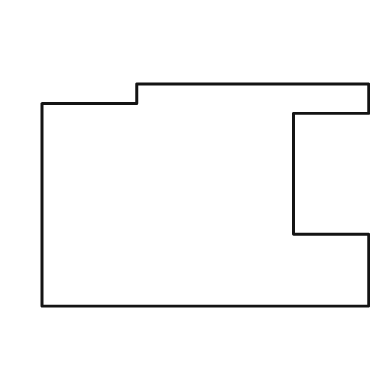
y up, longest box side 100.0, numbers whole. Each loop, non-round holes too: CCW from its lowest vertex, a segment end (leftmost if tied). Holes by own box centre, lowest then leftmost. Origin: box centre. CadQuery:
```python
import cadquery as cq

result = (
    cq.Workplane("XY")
    .moveTo(-50.0, -34.0)
    .lineTo(50.0, -34.0)
    .lineTo(50.0, -12.0)
    .lineTo(27.0, -12.0)
    .lineTo(27.0, 25.0)
    .lineTo(50.0, 25.0)
    .lineTo(50.0, 34.0)
    .lineTo(-21.0, 34.0)
    .lineTo(-21.0, 28.0)
    .lineTo(-50.0, 28.0)
    .close()
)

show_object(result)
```